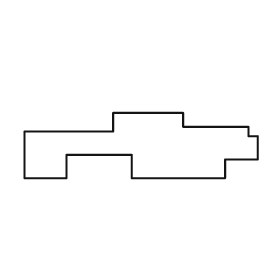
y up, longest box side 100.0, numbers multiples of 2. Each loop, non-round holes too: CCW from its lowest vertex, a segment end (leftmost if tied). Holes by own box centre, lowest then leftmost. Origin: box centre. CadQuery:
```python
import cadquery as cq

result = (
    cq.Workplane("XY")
    .moveTo(-50.0, -14.0)
    .lineTo(-32.0, -14.0)
    .lineTo(-32.0, -4.0)
    .lineTo(-4.0, -4.0)
    .lineTo(-4.0, -14.0)
    .lineTo(36.0, -14.0)
    .lineTo(36.0, -6.0)
    .lineTo(50.0, -6.0)
    .lineTo(50.0, 4.0)
    .lineTo(46.0, 4.0)
    .lineTo(46.0, 8.0)
    .lineTo(18.0, 8.0)
    .lineTo(18.0, 14.0)
    .lineTo(-12.0, 14.0)
    .lineTo(-12.0, 6.0)
    .lineTo(-50.0, 6.0)
    .close()
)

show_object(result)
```